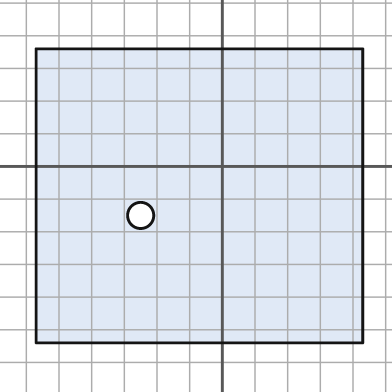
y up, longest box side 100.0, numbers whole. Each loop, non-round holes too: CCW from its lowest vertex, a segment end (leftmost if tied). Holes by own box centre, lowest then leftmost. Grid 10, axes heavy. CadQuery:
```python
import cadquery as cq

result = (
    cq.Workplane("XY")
    .moveTo(-57.0, -54.0)
    .lineTo(43.0, -54.0)
    .lineTo(43.0, 36.0)
    .lineTo(-57.0, 36.0)
    .close()
    .moveTo(-25.0, -15.0)
    .circle(4.0)
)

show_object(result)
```